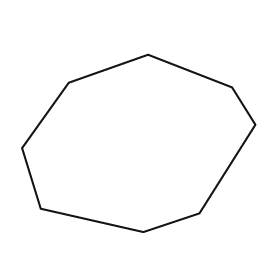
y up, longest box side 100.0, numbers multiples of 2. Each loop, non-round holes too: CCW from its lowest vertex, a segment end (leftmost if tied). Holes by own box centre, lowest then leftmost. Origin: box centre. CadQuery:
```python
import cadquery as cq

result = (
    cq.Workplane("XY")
    .moveTo(2.0, -38.0)
    .lineTo(26.0, -30.0)
    .lineTo(50.0, 8.0)
    .lineTo(40.0, 24.0)
    .lineTo(4.0, 38.0)
    .lineTo(-30.0, 26.0)
    .lineTo(-50.0, -2.0)
    .lineTo(-42.0, -28.0)
    .close()
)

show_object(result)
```